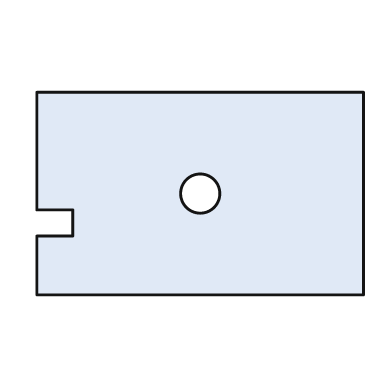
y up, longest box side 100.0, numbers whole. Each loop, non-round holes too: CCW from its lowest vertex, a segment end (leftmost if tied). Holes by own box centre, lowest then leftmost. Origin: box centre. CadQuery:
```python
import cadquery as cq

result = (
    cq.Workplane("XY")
    .moveTo(-50.0, -31.0)
    .lineTo(50.0, -31.0)
    .lineTo(50.0, 31.0)
    .lineTo(-50.0, 31.0)
    .lineTo(-50.0, -5.0)
    .lineTo(-39.0, -5.0)
    .lineTo(-39.0, -13.0)
    .lineTo(-50.0, -13.0)
    .close()
    .moveTo(0.0, 0.0)
    .circle(6.0)
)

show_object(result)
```